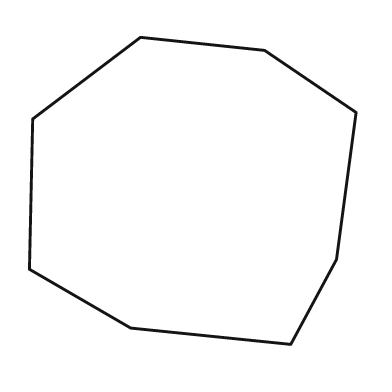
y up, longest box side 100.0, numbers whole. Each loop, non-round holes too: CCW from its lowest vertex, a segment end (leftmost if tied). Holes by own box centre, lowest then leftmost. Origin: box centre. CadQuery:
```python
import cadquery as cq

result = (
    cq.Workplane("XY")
    .moveTo(30.0, -47.0)
    .lineTo(44.0, -21.0)
    .lineTo(50.0, 24.0)
    .lineTo(22.0, 43.0)
    .lineTo(-16.0, 47.0)
    .lineTo(-49.0, 22.0)
    .lineTo(-50.0, -24.0)
    .lineTo(-19.0, -42.0)
    .close()
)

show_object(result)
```